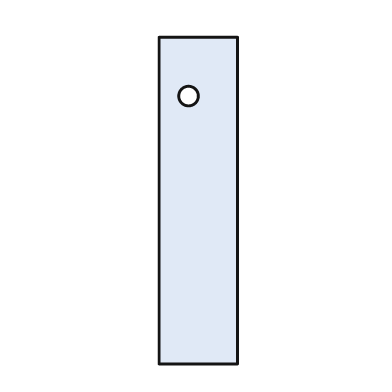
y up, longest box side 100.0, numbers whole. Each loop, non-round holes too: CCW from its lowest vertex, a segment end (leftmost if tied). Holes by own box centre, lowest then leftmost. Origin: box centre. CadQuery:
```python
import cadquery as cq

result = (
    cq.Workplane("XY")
    .moveTo(-12.0, -50.0)
    .lineTo(12.0, -50.0)
    .lineTo(12.0, 50.0)
    .lineTo(-12.0, 50.0)
    .close()
    .moveTo(-3.0, 32.0)
    .circle(3.0)
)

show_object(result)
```